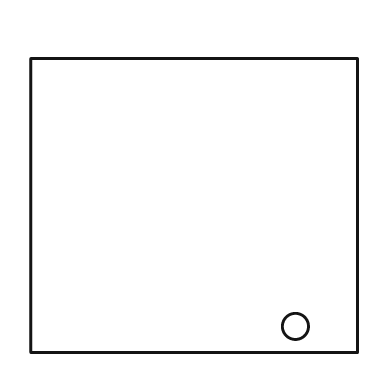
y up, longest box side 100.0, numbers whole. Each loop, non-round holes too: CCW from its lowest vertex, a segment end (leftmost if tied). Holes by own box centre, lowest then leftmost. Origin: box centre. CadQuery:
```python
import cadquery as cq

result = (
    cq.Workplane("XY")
    .moveTo(-50.0, -45.0)
    .lineTo(50.0, -45.0)
    .lineTo(50.0, 45.0)
    .lineTo(-50.0, 45.0)
    .close()
    .moveTo(31.0, -37.0)
    .circle(4.0)
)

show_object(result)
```